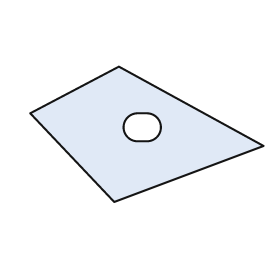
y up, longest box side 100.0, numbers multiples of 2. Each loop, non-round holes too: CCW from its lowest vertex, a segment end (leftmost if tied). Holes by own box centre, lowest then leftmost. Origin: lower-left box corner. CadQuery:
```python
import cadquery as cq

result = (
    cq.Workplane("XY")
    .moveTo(36.0, 0.0)
    .lineTo(100.0, 24.0)
    .lineTo(38.0, 58.0)
    .lineTo(0.0, 38.0)
    .close()
    .moveTo(46.0, 26.0)
    .lineTo(50.0, 26.0)
    .threePointArc((56.0, 32.0), (50.0, 38.0))
    .lineTo(46.0, 38.0)
    .threePointArc((40.0, 32.0), (46.0, 26.0))
    .close()
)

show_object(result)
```